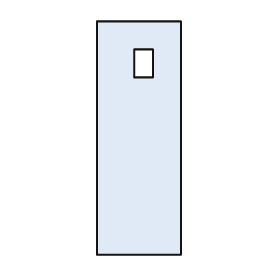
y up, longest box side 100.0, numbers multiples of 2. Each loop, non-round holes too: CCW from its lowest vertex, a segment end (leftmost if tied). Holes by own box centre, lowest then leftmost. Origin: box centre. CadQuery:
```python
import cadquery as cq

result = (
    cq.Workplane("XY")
    .moveTo(-18.0, -50.0)
    .lineTo(18.0, -50.0)
    .lineTo(18.0, 50.0)
    .lineTo(-18.0, 50.0)
    .close()
    .moveTo(-2.0, 26.0)
    .lineTo(6.0, 26.0)
    .lineTo(6.0, 38.0)
    .lineTo(-2.0, 38.0)
    .close()
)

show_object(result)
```